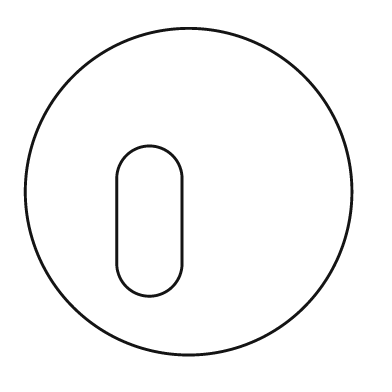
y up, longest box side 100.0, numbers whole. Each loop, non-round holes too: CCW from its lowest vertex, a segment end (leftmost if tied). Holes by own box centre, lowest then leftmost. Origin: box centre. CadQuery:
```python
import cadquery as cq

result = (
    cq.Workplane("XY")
    .moveTo(0.0, 0.0)
    .circle(50.0)
    .moveTo(-22.0, -22.0)
    .threePointArc((-12.0, -32.0), (-2.0, -22.0))
    .lineTo(-2.0, 4.0)
    .threePointArc((-12.0, 14.0), (-22.0, 4.0))
    .close()
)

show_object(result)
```